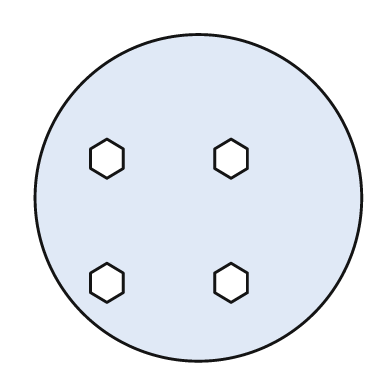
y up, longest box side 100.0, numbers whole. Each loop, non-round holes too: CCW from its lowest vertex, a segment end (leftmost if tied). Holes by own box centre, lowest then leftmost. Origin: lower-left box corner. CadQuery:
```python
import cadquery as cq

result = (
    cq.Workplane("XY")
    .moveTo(50.0, 50.0)
    .circle(50.0)
    .moveTo(22.0, 18.0)
    .lineTo(27.0, 21.0)
    .lineTo(27.0, 27.0)
    .lineTo(22.0, 30.0)
    .lineTo(17.0, 27.0)
    .lineTo(17.0, 21.0)
    .close()
    .moveTo(60.0, 18.0)
    .lineTo(65.0, 21.0)
    .lineTo(65.0, 27.0)
    .lineTo(60.0, 30.0)
    .lineTo(55.0, 27.0)
    .lineTo(55.0, 21.0)
    .close()
    .moveTo(22.0, 56.0)
    .lineTo(27.0, 59.0)
    .lineTo(27.0, 65.0)
    .lineTo(22.0, 68.0)
    .lineTo(17.0, 65.0)
    .lineTo(17.0, 59.0)
    .close()
    .moveTo(60.0, 56.0)
    .lineTo(65.0, 59.0)
    .lineTo(65.0, 65.0)
    .lineTo(60.0, 68.0)
    .lineTo(55.0, 65.0)
    .lineTo(55.0, 59.0)
    .close()
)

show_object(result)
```